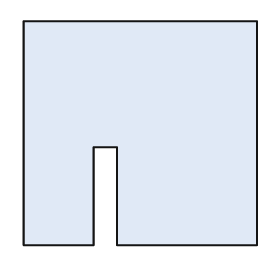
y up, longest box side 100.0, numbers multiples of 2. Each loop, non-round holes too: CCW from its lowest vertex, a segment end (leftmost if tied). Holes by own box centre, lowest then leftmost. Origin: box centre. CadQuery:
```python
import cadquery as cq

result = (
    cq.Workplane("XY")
    .moveTo(-50.0, -48.0)
    .lineTo(-20.0, -48.0)
    .lineTo(-20.0, -6.0)
    .lineTo(-10.0, -6.0)
    .lineTo(-10.0, -48.0)
    .lineTo(50.0, -48.0)
    .lineTo(50.0, 48.0)
    .lineTo(-50.0, 48.0)
    .close()
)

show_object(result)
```